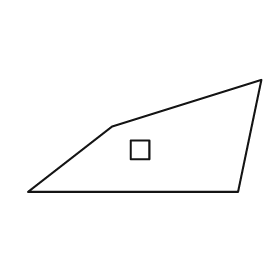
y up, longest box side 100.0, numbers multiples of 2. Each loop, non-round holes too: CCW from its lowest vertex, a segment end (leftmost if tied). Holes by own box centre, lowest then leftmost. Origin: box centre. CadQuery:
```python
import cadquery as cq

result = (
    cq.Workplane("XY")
    .moveTo(-50.0, -24.0)
    .lineTo(40.0, -24.0)
    .lineTo(50.0, 24.0)
    .lineTo(-14.0, 4.0)
    .close()
    .moveTo(-6.0, -10.0)
    .lineTo(2.0, -10.0)
    .lineTo(2.0, -2.0)
    .lineTo(-6.0, -2.0)
    .close()
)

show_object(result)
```